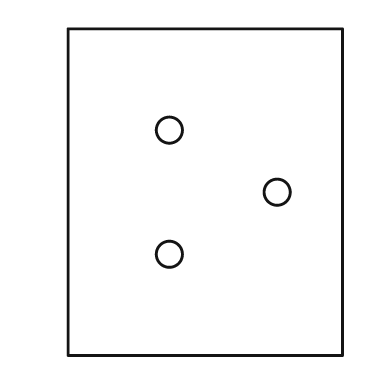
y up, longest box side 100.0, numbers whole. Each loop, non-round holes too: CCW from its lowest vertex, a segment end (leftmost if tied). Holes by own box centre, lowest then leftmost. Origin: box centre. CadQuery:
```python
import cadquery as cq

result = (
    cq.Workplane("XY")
    .moveTo(-42.0, -50.0)
    .lineTo(42.0, -50.0)
    .lineTo(42.0, 50.0)
    .lineTo(-42.0, 50.0)
    .close()
    .moveTo(-11.0, -19.0)
    .circle(4.0)
    .moveTo(22.0, 0.0)
    .circle(4.0)
    .moveTo(-11.0, 19.0)
    .circle(4.0)
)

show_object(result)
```